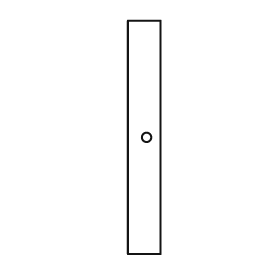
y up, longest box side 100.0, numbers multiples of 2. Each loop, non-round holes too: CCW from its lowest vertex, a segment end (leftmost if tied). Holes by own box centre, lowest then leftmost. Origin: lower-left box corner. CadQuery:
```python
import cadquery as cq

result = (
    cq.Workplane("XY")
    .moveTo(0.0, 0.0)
    .lineTo(14.0, 0.0)
    .lineTo(14.0, 100.0)
    .lineTo(0.0, 100.0)
    .close()
    .moveTo(8.0, 50.0)
    .circle(2.0)
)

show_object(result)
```